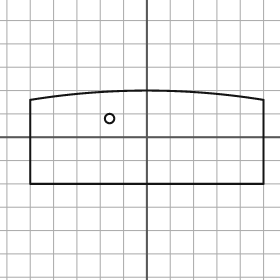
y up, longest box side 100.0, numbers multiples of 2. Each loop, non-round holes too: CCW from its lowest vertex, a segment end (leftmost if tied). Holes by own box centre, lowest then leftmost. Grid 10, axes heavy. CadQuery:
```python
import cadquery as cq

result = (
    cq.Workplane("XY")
    .moveTo(-50.0, -20.0)
    .lineTo(50.0, -20.0)
    .lineTo(50.0, 16.0)
    .threePointArc((0.0, 20.0), (-50.0, 16.0))
    .close()
    .moveTo(-16.0, 8.0)
    .circle(2.0)
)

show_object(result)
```